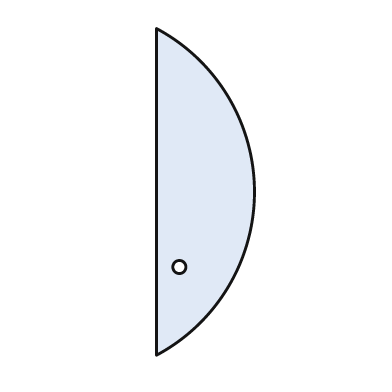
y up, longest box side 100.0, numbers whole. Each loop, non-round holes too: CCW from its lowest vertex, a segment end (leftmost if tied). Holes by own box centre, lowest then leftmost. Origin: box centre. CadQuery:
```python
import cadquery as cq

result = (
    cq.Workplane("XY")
    .moveTo(-15.0, -50.0)
    .threePointArc((15.0, 0.0), (-15.0, 50.0))
    .close()
    .moveTo(-8.0, -23.0)
    .circle(2.0)
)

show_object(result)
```